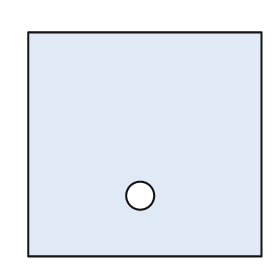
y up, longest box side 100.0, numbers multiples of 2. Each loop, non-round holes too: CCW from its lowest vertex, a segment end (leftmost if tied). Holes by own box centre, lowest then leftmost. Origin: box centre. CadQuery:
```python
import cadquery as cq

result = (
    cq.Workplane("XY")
    .moveTo(-50.0, -48.0)
    .lineTo(50.0, -48.0)
    .lineTo(50.0, 48.0)
    .lineTo(-50.0, 48.0)
    .close()
    .moveTo(-2.0, -22.0)
    .circle(6.0)
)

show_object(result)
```